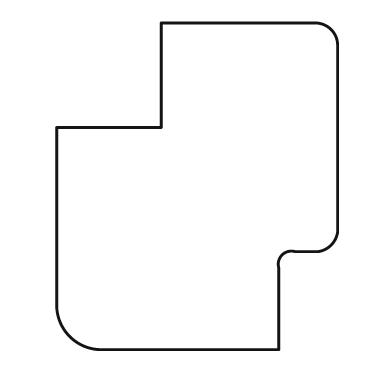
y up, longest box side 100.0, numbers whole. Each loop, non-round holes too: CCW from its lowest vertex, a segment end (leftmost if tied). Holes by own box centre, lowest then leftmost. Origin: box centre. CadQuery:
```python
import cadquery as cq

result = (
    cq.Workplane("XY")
    .moveTo(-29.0, -50.0)
    .lineTo(25.0, -50.0)
    .lineTo(25.0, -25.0)
    .threePointArc((26.0, -21.0), (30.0, -20.0))
    .lineTo(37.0, -20.0)
    .threePointArc((41.0, -18.0), (43.0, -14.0))
    .lineTo(43.0, 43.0)
    .threePointArc((41.0, 48.0), (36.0, 50.0))
    .lineTo(-11.0, 50.0)
    .lineTo(-11.0, 18.0)
    .lineTo(-43.0, 18.0)
    .lineTo(-43.0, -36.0)
    .threePointArc((-39.0, -46.0), (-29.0, -50.0))
    .close()
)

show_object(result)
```